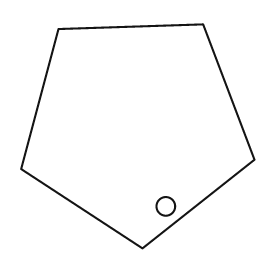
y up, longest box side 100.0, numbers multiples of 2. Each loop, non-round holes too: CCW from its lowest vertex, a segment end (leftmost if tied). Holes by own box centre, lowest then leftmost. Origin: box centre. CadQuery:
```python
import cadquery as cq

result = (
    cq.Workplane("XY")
    .moveTo(2.0, -48.0)
    .lineTo(50.0, -10.0)
    .lineTo(28.0, 48.0)
    .lineTo(-34.0, 46.0)
    .lineTo(-50.0, -14.0)
    .close()
    .moveTo(12.0, -30.0)
    .circle(4.0)
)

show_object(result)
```